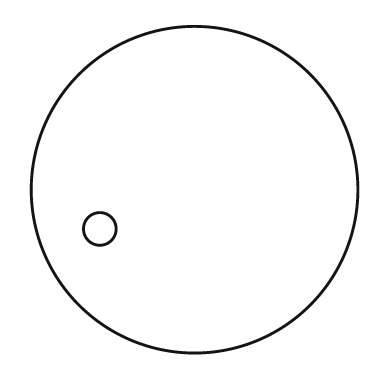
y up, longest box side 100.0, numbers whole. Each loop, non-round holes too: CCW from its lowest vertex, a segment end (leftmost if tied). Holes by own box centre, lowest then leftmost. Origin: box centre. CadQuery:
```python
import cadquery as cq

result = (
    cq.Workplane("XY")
    .moveTo(0.0, 0.0)
    .circle(50.0)
    .moveTo(-29.0, -12.0)
    .circle(5.0)
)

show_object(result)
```